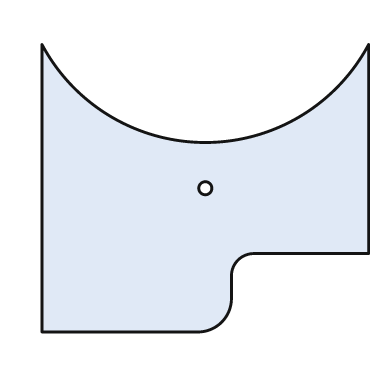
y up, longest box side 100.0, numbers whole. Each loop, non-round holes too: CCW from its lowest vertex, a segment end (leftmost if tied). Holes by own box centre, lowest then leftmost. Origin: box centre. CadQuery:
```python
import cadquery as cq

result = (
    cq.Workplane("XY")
    .moveTo(-50.0, -44.0)
    .lineTo(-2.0, -44.0)
    .threePointArc((5.0, -41.0), (8.0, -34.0))
    .lineTo(8.0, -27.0)
    .threePointArc((10.0, -22.0), (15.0, -20.0))
    .lineTo(50.0, -20.0)
    .lineTo(50.0, 44.0)
    .threePointArc((0.0, 14.0), (-50.0, 44.0))
    .close()
    .moveTo(0.0, 0.0)
    .circle(2.0)
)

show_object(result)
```